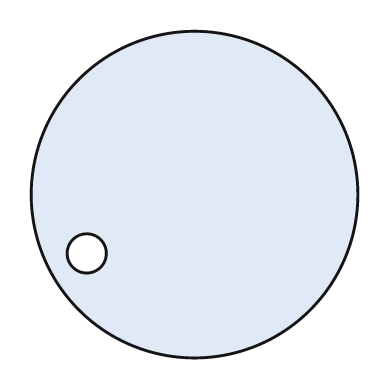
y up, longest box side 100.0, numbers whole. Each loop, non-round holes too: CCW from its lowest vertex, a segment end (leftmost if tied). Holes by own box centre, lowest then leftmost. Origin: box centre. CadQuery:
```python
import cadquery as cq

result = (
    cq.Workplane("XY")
    .moveTo(0.0, 0.0)
    .circle(50.0)
    .moveTo(-33.0, -18.0)
    .circle(6.0)
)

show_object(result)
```